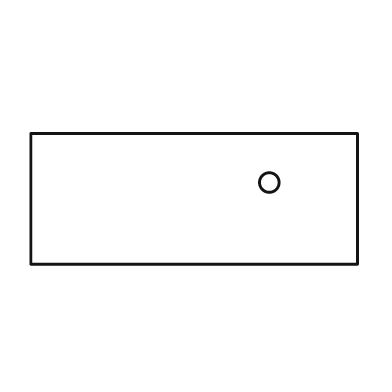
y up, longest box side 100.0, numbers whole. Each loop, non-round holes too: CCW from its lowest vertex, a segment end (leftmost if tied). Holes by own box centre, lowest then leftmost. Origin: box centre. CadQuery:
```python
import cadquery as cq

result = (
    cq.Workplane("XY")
    .moveTo(-50.0, -20.0)
    .lineTo(50.0, -20.0)
    .lineTo(50.0, 20.0)
    .lineTo(-50.0, 20.0)
    .close()
    .moveTo(23.0, 5.0)
    .circle(3.0)
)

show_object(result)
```